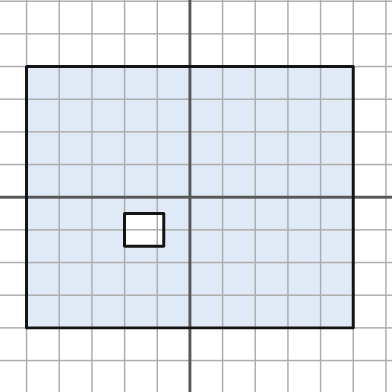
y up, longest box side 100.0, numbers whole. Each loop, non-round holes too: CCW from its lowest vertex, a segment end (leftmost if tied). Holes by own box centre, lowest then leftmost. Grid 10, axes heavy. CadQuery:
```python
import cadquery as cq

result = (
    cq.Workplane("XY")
    .moveTo(-50.0, -40.0)
    .lineTo(50.0, -40.0)
    .lineTo(50.0, 40.0)
    .lineTo(-50.0, 40.0)
    .close()
    .moveTo(-20.0, -15.0)
    .lineTo(-8.0, -15.0)
    .lineTo(-8.0, -5.0)
    .lineTo(-20.0, -5.0)
    .close()
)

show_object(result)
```